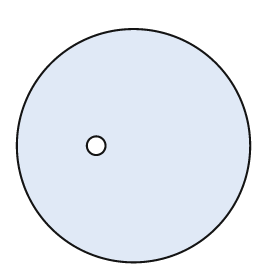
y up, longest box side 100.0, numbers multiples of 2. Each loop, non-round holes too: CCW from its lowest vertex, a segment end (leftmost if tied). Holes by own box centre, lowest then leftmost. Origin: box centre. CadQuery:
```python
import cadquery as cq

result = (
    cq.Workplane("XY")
    .moveTo(0.0, 0.0)
    .circle(50.0)
    .moveTo(-16.0, 0.0)
    .circle(4.0)
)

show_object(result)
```